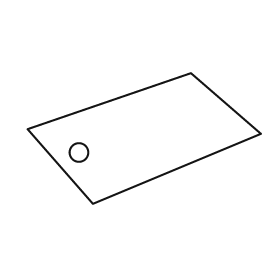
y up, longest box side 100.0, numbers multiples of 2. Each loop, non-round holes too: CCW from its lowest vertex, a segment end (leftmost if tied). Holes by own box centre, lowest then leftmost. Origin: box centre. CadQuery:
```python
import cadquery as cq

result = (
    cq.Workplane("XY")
    .moveTo(-22.0, -28.0)
    .lineTo(50.0, 2.0)
    .lineTo(20.0, 28.0)
    .lineTo(-50.0, 4.0)
    .close()
    .moveTo(-28.0, -6.0)
    .circle(4.0)
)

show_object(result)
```